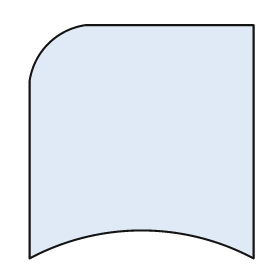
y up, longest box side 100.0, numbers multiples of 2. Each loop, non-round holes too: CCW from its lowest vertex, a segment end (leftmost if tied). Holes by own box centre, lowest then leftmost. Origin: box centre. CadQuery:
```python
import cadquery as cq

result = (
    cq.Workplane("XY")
    .moveTo(-48.0, -50.0)
    .threePointArc((0.0, -38.0), (48.0, -50.0))
    .lineTo(48.0, 50.0)
    .lineTo(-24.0, 50.0)
    .threePointArc((-40.0, 42.0), (-48.0, 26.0))
    .close()
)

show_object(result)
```